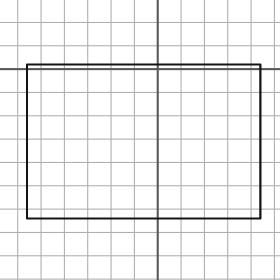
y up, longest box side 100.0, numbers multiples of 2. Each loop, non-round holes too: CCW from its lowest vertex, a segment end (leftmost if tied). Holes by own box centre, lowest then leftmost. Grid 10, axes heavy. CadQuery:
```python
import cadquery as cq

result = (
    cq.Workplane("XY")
    .moveTo(-56.0, -64.0)
    .lineTo(44.0, -64.0)
    .lineTo(44.0, 2.0)
    .lineTo(-56.0, 2.0)
    .close()
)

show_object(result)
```